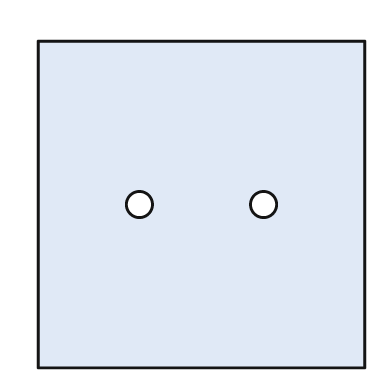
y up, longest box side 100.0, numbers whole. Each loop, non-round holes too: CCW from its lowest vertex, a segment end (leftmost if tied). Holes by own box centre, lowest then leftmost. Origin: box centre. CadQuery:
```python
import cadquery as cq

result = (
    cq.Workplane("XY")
    .moveTo(-50.0, -50.0)
    .lineTo(50.0, -50.0)
    .lineTo(50.0, 50.0)
    .lineTo(-50.0, 50.0)
    .close()
    .moveTo(-19.0, 0.0)
    .circle(4.0)
    .moveTo(19.0, 0.0)
    .circle(4.0)
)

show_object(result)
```